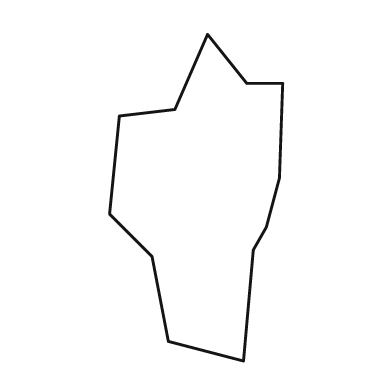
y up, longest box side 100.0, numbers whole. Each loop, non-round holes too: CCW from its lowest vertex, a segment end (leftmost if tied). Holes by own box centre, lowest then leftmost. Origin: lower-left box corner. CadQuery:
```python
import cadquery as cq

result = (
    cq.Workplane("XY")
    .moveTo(41.0, 0.0)
    .lineTo(44.0, 34.0)
    .lineTo(48.0, 41.0)
    .lineTo(52.0, 56.0)
    .lineTo(53.0, 85.0)
    .lineTo(42.0, 85.0)
    .lineTo(30.0, 100.0)
    .lineTo(20.0, 77.0)
    .lineTo(3.0, 75.0)
    .lineTo(0.0, 45.0)
    .lineTo(13.0, 32.0)
    .lineTo(18.0, 6.0)
    .close()
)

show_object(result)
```